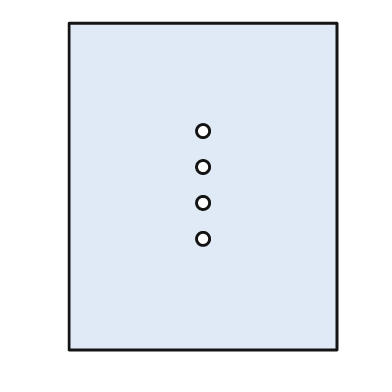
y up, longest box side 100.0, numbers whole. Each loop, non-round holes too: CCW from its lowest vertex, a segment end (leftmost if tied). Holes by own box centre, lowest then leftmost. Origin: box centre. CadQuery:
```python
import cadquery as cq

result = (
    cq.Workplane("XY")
    .moveTo(-41.0, -50.0)
    .lineTo(41.0, -50.0)
    .lineTo(41.0, 50.0)
    .lineTo(-41.0, 50.0)
    .close()
    .moveTo(0.0, -16.0)
    .circle(2.0)
    .moveTo(0.0, -5.0)
    .circle(2.0)
    .moveTo(0.0, 6.0)
    .circle(2.0)
    .moveTo(0.0, 17.0)
    .circle(2.0)
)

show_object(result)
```